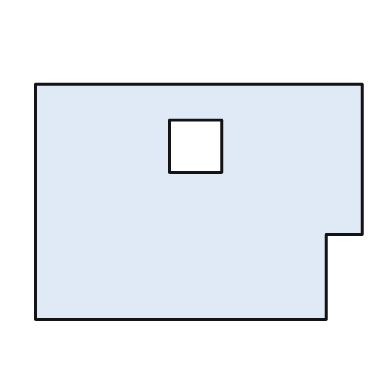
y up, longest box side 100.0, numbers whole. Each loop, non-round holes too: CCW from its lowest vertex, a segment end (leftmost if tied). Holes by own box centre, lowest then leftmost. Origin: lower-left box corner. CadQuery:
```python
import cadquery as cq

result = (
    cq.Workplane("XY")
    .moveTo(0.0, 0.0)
    .lineTo(89.0, 0.0)
    .lineTo(89.0, 26.0)
    .lineTo(100.0, 26.0)
    .lineTo(100.0, 72.0)
    .lineTo(0.0, 72.0)
    .close()
    .moveTo(41.0, 45.0)
    .lineTo(57.0, 45.0)
    .lineTo(57.0, 61.0)
    .lineTo(41.0, 61.0)
    .close()
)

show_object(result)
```